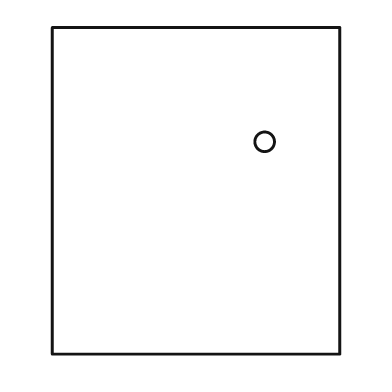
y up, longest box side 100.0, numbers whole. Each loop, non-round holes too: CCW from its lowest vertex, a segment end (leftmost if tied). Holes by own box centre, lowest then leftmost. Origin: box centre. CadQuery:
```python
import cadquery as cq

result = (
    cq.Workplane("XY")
    .moveTo(-44.0, -50.0)
    .lineTo(44.0, -50.0)
    .lineTo(44.0, 50.0)
    .lineTo(-44.0, 50.0)
    .close()
    .moveTo(21.0, 15.0)
    .circle(3.0)
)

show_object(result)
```